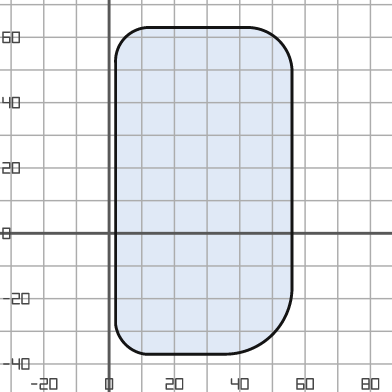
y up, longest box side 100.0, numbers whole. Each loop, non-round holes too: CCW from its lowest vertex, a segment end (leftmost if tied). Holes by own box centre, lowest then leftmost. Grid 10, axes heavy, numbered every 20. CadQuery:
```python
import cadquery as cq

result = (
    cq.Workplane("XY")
    .moveTo(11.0, -37.0)
    .lineTo(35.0, -37.0)
    .threePointArc((50.0, -31.0), (56.0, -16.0))
    .lineTo(56.0, 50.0)
    .threePointArc((52.0, 59.0), (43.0, 63.0))
    .lineTo(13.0, 63.0)
    .threePointArc((5.0, 60.0), (2.0, 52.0))
    .lineTo(2.0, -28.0)
    .threePointArc((5.0, -34.0), (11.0, -37.0))
    .close()
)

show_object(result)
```